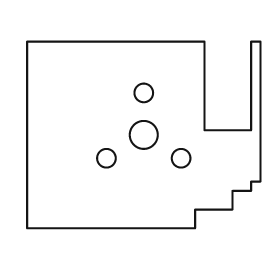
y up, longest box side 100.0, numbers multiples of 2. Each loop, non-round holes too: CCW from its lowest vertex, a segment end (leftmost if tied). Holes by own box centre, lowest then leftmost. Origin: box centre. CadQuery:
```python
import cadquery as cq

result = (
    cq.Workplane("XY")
    .moveTo(-50.0, -40.0)
    .lineTo(22.0, -40.0)
    .lineTo(22.0, -32.0)
    .lineTo(38.0, -32.0)
    .lineTo(38.0, -24.0)
    .lineTo(46.0, -24.0)
    .lineTo(46.0, -20.0)
    .lineTo(50.0, -20.0)
    .lineTo(50.0, 40.0)
    .lineTo(46.0, 40.0)
    .lineTo(46.0, 2.0)
    .lineTo(26.0, 2.0)
    .lineTo(26.0, 40.0)
    .lineTo(-50.0, 40.0)
    .close()
    .moveTo(-16.0, -10.0)
    .circle(4.0)
    .moveTo(16.0, -10.0)
    .circle(4.0)
    .moveTo(0.0, 0.0)
    .circle(6.0)
    .moveTo(0.0, 18.0)
    .circle(4.0)
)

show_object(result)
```